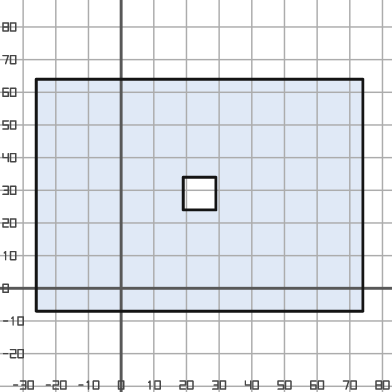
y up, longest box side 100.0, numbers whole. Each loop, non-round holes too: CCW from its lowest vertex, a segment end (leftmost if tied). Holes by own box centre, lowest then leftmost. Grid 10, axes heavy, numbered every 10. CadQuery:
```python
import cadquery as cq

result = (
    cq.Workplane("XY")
    .moveTo(-26.0, -7.0)
    .lineTo(74.0, -7.0)
    .lineTo(74.0, 64.0)
    .lineTo(-26.0, 64.0)
    .close()
    .moveTo(19.0, 24.0)
    .lineTo(29.0, 24.0)
    .lineTo(29.0, 34.0)
    .lineTo(19.0, 34.0)
    .close()
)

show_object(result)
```